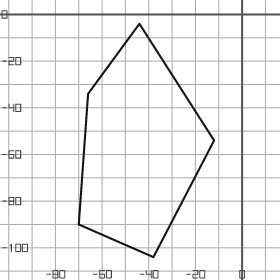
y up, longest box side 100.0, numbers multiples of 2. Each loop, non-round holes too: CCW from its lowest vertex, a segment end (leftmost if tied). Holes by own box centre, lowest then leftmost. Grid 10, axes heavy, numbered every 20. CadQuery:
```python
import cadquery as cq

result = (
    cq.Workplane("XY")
    .moveTo(-38.0, -104.0)
    .lineTo(-12.0, -54.0)
    .lineTo(-44.0, -4.0)
    .lineTo(-66.0, -34.0)
    .lineTo(-70.0, -90.0)
    .close()
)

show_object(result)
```